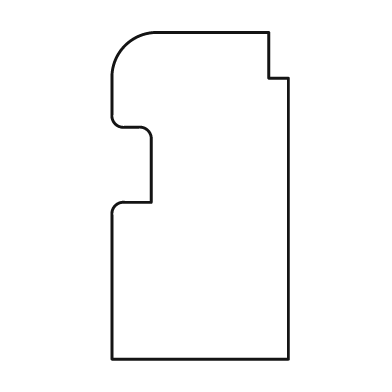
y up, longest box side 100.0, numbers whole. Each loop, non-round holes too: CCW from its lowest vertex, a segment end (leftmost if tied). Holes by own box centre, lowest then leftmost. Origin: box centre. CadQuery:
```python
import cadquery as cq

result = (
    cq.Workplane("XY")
    .moveTo(-27.0, -50.0)
    .lineTo(27.0, -50.0)
    .lineTo(27.0, 36.0)
    .lineTo(21.0, 36.0)
    .lineTo(21.0, 50.0)
    .lineTo(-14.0, 50.0)
    .threePointArc((-23.0, 46.0), (-27.0, 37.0))
    .lineTo(-27.0, 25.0)
    .threePointArc((-26.0, 22.0), (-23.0, 21.0))
    .lineTo(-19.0, 21.0)
    .threePointArc((-16.0, 20.0), (-15.0, 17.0))
    .lineTo(-15.0, -2.0)
    .lineTo(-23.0, -2.0)
    .threePointArc((-26.0, -3.0), (-27.0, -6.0))
    .close()
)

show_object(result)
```